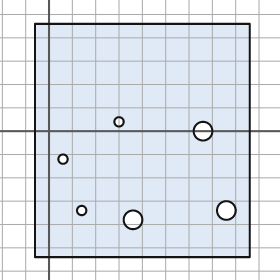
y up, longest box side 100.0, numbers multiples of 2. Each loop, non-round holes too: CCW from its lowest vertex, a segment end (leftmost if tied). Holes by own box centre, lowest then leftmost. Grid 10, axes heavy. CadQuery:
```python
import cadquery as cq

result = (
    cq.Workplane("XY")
    .moveTo(-6.0, -54.0)
    .lineTo(86.0, -54.0)
    .lineTo(86.0, 46.0)
    .lineTo(-6.0, 46.0)
    .close()
    .moveTo(36.0, -38.0)
    .circle(4.0)
    .moveTo(14.0, -34.0)
    .circle(2.0)
    .moveTo(76.0, -34.0)
    .circle(4.0)
    .moveTo(6.0, -12.0)
    .circle(2.0)
    .moveTo(66.0, 0.0)
    .circle(4.0)
    .moveTo(30.0, 4.0)
    .circle(2.0)
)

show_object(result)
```